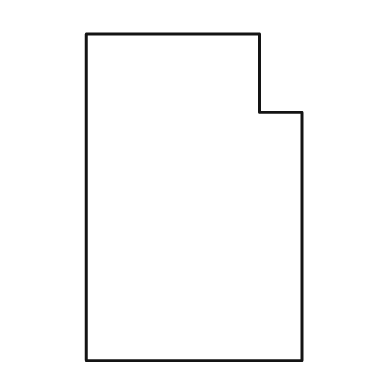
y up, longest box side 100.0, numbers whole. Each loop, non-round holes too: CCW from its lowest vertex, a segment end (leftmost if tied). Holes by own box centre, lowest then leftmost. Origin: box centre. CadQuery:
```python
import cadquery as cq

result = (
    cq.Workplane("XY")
    .moveTo(-33.0, -50.0)
    .lineTo(33.0, -50.0)
    .lineTo(33.0, 26.0)
    .lineTo(20.0, 26.0)
    .lineTo(20.0, 50.0)
    .lineTo(-33.0, 50.0)
    .close()
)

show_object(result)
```